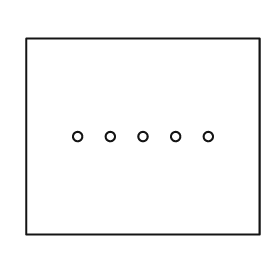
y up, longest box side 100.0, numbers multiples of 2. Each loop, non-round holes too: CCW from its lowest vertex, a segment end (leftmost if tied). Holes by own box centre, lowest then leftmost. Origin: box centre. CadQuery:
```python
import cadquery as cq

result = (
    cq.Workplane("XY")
    .moveTo(-50.0, -42.0)
    .lineTo(50.0, -42.0)
    .lineTo(50.0, 42.0)
    .lineTo(-50.0, 42.0)
    .close()
    .moveTo(-28.0, 0.0)
    .circle(2.0)
    .moveTo(-14.0, 0.0)
    .circle(2.0)
    .moveTo(0.0, 0.0)
    .circle(2.0)
    .moveTo(14.0, 0.0)
    .circle(2.0)
    .moveTo(28.0, 0.0)
    .circle(2.0)
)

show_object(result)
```